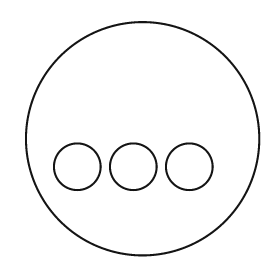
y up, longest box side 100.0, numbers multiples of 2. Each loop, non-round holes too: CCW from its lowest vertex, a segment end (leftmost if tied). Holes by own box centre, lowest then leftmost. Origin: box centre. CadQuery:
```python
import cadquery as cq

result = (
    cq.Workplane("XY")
    .moveTo(0.0, 0.0)
    .circle(50.0)
    .moveTo(-28.0, -12.0)
    .circle(10.0)
    .moveTo(-4.0, -12.0)
    .circle(10.0)
    .moveTo(20.0, -12.0)
    .circle(10.0)
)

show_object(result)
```